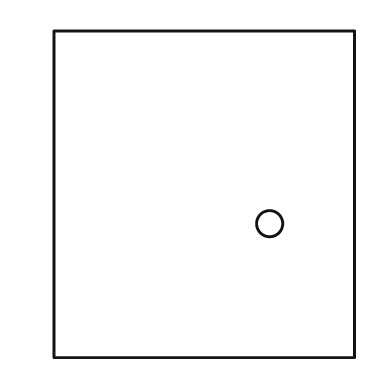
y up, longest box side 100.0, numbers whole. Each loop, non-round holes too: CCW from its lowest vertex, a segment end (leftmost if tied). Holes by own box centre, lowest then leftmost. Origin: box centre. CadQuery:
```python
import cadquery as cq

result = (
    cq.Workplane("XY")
    .moveTo(-46.0, -50.0)
    .lineTo(46.0, -50.0)
    .lineTo(46.0, 50.0)
    .lineTo(-46.0, 50.0)
    .close()
    .moveTo(20.0, -9.0)
    .circle(4.0)
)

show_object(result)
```